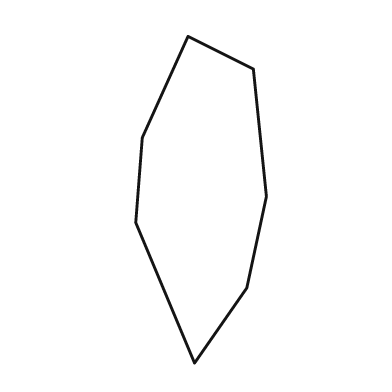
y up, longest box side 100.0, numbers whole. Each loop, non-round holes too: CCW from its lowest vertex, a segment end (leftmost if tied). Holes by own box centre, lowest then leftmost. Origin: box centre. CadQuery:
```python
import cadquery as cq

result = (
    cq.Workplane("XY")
    .moveTo(-2.0, -50.0)
    .lineTo(14.0, -27.0)
    .lineTo(20.0, 1.0)
    .lineTo(16.0, 40.0)
    .lineTo(-4.0, 50.0)
    .lineTo(-18.0, 19.0)
    .lineTo(-20.0, -7.0)
    .close()
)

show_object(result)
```